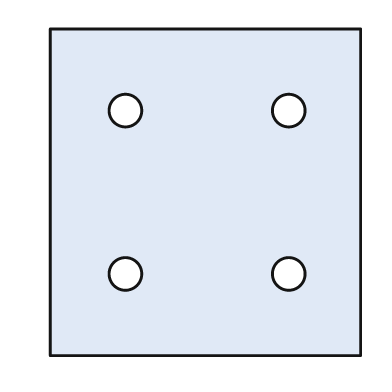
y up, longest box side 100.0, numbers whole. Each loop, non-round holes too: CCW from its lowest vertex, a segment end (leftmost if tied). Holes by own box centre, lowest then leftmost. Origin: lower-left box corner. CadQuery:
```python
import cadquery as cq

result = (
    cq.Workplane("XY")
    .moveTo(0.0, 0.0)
    .lineTo(95.0, 0.0)
    .lineTo(95.0, 100.0)
    .lineTo(0.0, 100.0)
    .close()
    .moveTo(23.0, 25.0)
    .circle(5.0)
    .moveTo(73.0, 25.0)
    .circle(5.0)
    .moveTo(23.0, 75.0)
    .circle(5.0)
    .moveTo(73.0, 75.0)
    .circle(5.0)
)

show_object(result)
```